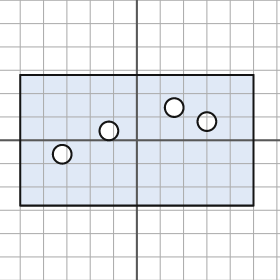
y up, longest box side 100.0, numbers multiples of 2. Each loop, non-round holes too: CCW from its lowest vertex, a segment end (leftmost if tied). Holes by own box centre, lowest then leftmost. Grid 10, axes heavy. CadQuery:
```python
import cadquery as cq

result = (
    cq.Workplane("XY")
    .moveTo(-50.0, -28.0)
    .lineTo(50.0, -28.0)
    .lineTo(50.0, 28.0)
    .lineTo(-50.0, 28.0)
    .close()
    .moveTo(-32.0, -6.0)
    .circle(4.0)
    .moveTo(-12.0, 4.0)
    .circle(4.0)
    .moveTo(30.0, 8.0)
    .circle(4.0)
    .moveTo(16.0, 14.0)
    .circle(4.0)
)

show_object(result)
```